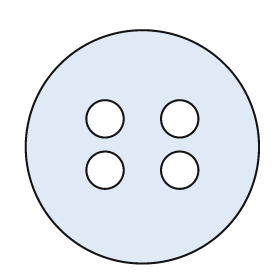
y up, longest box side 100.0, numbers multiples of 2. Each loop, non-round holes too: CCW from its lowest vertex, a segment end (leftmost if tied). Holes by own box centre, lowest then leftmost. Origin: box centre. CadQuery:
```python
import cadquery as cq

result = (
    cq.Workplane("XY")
    .moveTo(0.0, 0.0)
    .circle(50.0)
    .moveTo(-16.0, -10.0)
    .circle(8.0)
    .moveTo(16.0, -10.0)
    .circle(8.0)
    .moveTo(-16.0, 12.0)
    .circle(8.0)
    .moveTo(16.0, 12.0)
    .circle(8.0)
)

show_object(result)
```